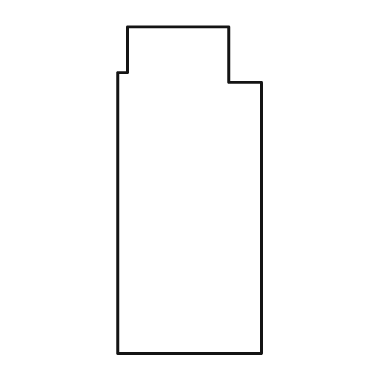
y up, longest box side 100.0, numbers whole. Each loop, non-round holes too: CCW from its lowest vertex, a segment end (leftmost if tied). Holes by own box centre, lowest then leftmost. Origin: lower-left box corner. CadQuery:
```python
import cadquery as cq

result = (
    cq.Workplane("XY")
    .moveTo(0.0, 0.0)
    .lineTo(44.0, 0.0)
    .lineTo(44.0, 83.0)
    .lineTo(34.0, 83.0)
    .lineTo(34.0, 100.0)
    .lineTo(3.0, 100.0)
    .lineTo(3.0, 86.0)
    .lineTo(0.0, 86.0)
    .close()
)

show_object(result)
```